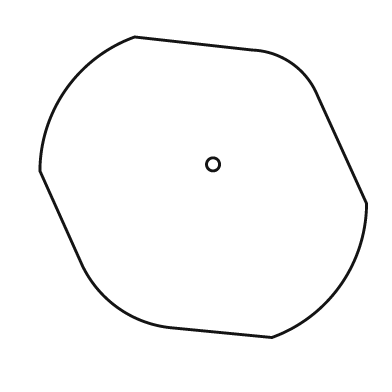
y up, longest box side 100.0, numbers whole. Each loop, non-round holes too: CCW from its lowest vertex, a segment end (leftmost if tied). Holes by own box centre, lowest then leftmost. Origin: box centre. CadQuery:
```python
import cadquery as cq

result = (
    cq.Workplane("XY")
    .moveTo(21.0, -46.0)
    .threePointArc((42.0, -30.0), (50.0, -5.0))
    .lineTo(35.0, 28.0)
    .threePointArc((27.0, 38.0), (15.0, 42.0))
    .lineTo(-21.0, 46.0)
    .threePointArc((-42.0, 30.0), (-50.0, 5.0))
    .lineTo(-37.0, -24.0)
    .threePointArc((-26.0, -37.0), (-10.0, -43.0))
    .close()
    .moveTo(3.0, 7.0)
    .circle(2.0)
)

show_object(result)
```